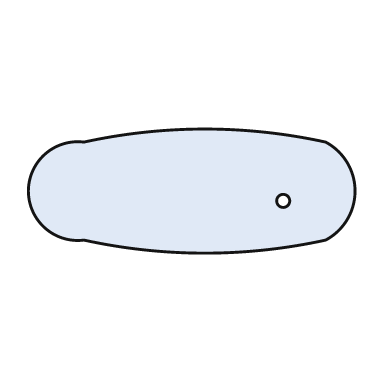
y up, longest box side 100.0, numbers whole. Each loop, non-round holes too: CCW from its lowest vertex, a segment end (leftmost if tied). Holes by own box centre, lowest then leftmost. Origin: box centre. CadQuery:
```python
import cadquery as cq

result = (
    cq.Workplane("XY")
    .moveTo(-33.0, -15.0)
    .threePointArc((4.0, -19.0), (41.0, -15.0))
    .threePointArc((50.0, 0.0), (41.0, 15.0))
    .threePointArc((4.0, 19.0), (-33.0, 15.0))
    .threePointArc((-50.0, 0.0), (-33.0, -15.0))
    .close()
    .moveTo(28.0, -3.0)
    .circle(2.0)
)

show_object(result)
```